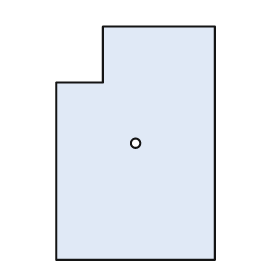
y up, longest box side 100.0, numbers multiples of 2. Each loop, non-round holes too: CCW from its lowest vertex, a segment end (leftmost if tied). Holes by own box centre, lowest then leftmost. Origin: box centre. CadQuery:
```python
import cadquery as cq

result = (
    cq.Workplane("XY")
    .moveTo(-34.0, -50.0)
    .lineTo(34.0, -50.0)
    .lineTo(34.0, 50.0)
    .lineTo(-14.0, 50.0)
    .lineTo(-14.0, 26.0)
    .lineTo(-34.0, 26.0)
    .close()
    .moveTo(0.0, 0.0)
    .circle(2.0)
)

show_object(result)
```